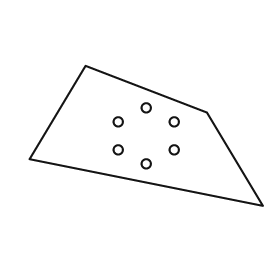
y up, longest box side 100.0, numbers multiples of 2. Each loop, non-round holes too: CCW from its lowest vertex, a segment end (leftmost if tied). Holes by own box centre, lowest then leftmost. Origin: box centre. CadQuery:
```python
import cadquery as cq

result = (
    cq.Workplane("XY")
    .moveTo(50.0, -30.0)
    .lineTo(26.0, 10.0)
    .lineTo(-26.0, 30.0)
    .lineTo(-50.0, -10.0)
    .close()
    .moveTo(0.0, -12.0)
    .circle(2.0)
    .moveTo(-12.0, -6.0)
    .circle(2.0)
    .moveTo(12.0, -6.0)
    .circle(2.0)
    .moveTo(-12.0, 6.0)
    .circle(2.0)
    .moveTo(12.0, 6.0)
    .circle(2.0)
    .moveTo(0.0, 12.0)
    .circle(2.0)
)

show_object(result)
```